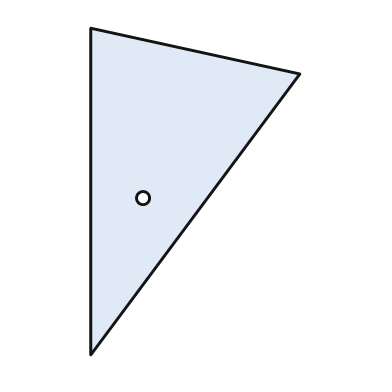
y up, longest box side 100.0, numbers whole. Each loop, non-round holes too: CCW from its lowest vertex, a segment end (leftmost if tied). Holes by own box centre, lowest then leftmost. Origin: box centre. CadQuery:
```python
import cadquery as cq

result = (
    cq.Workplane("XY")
    .moveTo(-32.0, -50.0)
    .lineTo(32.0, 36.0)
    .lineTo(-32.0, 50.0)
    .close()
    .moveTo(-16.0, -2.0)
    .circle(2.0)
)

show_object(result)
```